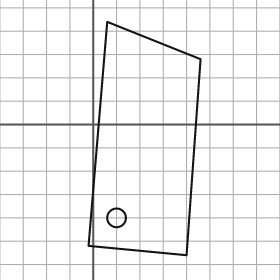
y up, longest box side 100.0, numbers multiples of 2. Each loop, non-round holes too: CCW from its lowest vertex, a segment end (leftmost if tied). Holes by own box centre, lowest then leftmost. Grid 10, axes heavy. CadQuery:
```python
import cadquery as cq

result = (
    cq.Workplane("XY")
    .moveTo(40.0, -56.0)
    .lineTo(46.0, 28.0)
    .lineTo(6.0, 44.0)
    .lineTo(-2.0, -52.0)
    .close()
    .moveTo(10.0, -40.0)
    .circle(4.0)
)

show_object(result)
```